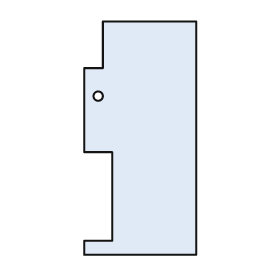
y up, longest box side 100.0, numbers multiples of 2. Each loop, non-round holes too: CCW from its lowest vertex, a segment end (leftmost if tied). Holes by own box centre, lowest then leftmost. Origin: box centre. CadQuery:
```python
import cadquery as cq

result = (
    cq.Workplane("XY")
    .moveTo(-24.0, -50.0)
    .lineTo(24.0, -50.0)
    .lineTo(24.0, 50.0)
    .lineTo(-16.0, 50.0)
    .lineTo(-16.0, 30.0)
    .lineTo(-24.0, 30.0)
    .lineTo(-24.0, -6.0)
    .lineTo(-12.0, -6.0)
    .lineTo(-12.0, -44.0)
    .lineTo(-24.0, -44.0)
    .close()
    .moveTo(-18.0, 18.0)
    .circle(2.0)
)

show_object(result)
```